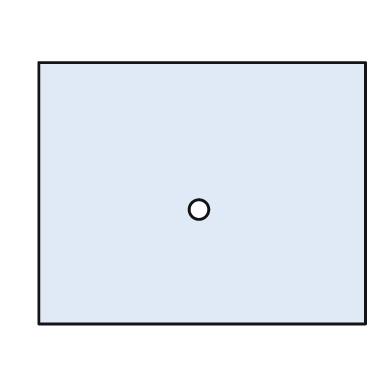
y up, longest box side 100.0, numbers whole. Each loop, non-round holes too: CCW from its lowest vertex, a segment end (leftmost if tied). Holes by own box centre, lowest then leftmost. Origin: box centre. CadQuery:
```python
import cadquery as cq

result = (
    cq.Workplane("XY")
    .moveTo(-50.0, -40.0)
    .lineTo(50.0, -40.0)
    .lineTo(50.0, 40.0)
    .lineTo(-50.0, 40.0)
    .close()
    .moveTo(-1.0, -5.0)
    .circle(3.0)
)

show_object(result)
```